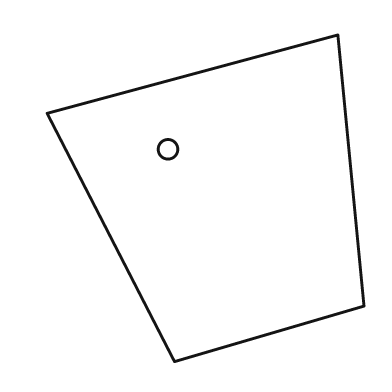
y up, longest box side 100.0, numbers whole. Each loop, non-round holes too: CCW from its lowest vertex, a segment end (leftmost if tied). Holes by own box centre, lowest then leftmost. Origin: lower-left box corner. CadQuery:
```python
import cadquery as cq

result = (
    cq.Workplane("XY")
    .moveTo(39.0, 0.0)
    .lineTo(97.0, 17.0)
    .lineTo(89.0, 100.0)
    .lineTo(0.0, 76.0)
    .close()
    .moveTo(37.0, 65.0)
    .circle(3.0)
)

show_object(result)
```